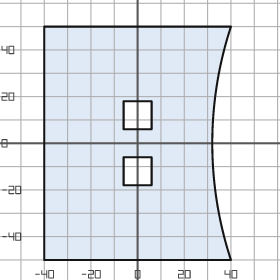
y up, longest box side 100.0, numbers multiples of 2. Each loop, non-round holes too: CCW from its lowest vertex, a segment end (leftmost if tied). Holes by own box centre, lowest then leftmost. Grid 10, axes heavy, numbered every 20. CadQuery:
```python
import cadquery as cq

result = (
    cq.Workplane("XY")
    .moveTo(-40.0, -50.0)
    .lineTo(40.0, -50.0)
    .threePointArc((32.0, 0.0), (40.0, 50.0))
    .lineTo(-40.0, 50.0)
    .close()
    .moveTo(-6.0, -18.0)
    .lineTo(6.0, -18.0)
    .lineTo(6.0, -6.0)
    .lineTo(-6.0, -6.0)
    .close()
    .moveTo(-6.0, 6.0)
    .lineTo(6.0, 6.0)
    .lineTo(6.0, 18.0)
    .lineTo(-6.0, 18.0)
    .close()
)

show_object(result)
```